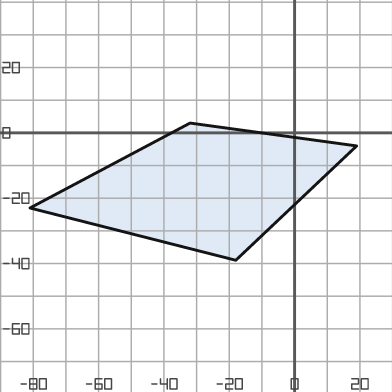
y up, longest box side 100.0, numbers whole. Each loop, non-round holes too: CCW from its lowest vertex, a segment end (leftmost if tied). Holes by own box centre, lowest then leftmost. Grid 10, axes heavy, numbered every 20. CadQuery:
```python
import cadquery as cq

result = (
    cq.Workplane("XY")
    .moveTo(-18.0, -39.0)
    .lineTo(19.0, -4.0)
    .lineTo(-32.0, 3.0)
    .lineTo(-81.0, -23.0)
    .close()
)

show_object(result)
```